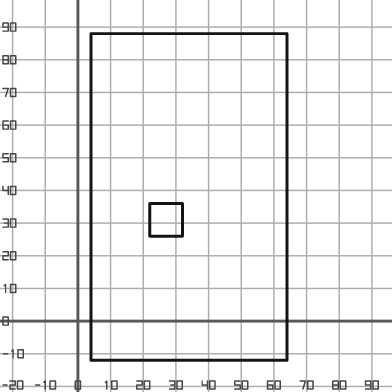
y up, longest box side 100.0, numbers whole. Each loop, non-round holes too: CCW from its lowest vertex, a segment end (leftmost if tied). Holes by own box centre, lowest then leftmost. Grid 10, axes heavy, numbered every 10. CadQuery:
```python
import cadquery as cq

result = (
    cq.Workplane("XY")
    .moveTo(4.0, -12.0)
    .lineTo(64.0, -12.0)
    .lineTo(64.0, 88.0)
    .lineTo(4.0, 88.0)
    .close()
    .moveTo(22.0, 26.0)
    .lineTo(32.0, 26.0)
    .lineTo(32.0, 36.0)
    .lineTo(22.0, 36.0)
    .close()
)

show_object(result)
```